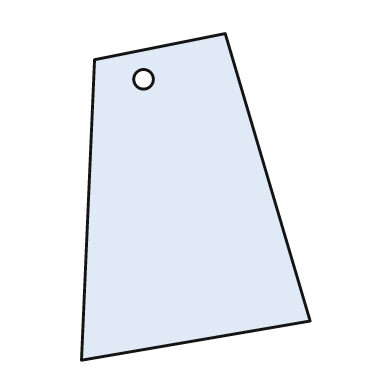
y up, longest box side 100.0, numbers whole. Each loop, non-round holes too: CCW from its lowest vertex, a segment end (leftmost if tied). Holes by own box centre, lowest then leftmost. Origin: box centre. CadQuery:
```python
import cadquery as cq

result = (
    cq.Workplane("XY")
    .moveTo(-35.0, -50.0)
    .lineTo(35.0, -38.0)
    .lineTo(9.0, 50.0)
    .lineTo(-31.0, 42.0)
    .close()
    .moveTo(-16.0, 36.0)
    .circle(3.0)
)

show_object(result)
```